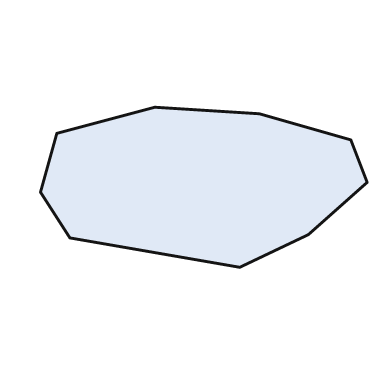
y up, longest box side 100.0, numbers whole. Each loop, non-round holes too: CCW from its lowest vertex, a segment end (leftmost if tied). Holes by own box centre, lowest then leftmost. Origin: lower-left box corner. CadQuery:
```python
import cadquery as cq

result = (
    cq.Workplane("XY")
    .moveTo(61.0, 0.0)
    .lineTo(82.0, 10.0)
    .lineTo(100.0, 26.0)
    .lineTo(95.0, 39.0)
    .lineTo(67.0, 47.0)
    .lineTo(35.0, 49.0)
    .lineTo(5.0, 41.0)
    .lineTo(0.0, 23.0)
    .lineTo(9.0, 9.0)
    .close()
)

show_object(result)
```